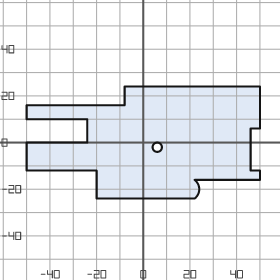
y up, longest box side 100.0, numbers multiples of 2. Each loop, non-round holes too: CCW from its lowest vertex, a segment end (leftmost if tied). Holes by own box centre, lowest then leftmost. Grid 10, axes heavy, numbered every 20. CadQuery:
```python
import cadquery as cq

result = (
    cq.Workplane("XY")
    .moveTo(-20.0, -24.0)
    .lineTo(22.0, -24.0)
    .threePointArc((24.0, -20.0), (22.0, -16.0))
    .lineTo(50.0, -16.0)
    .lineTo(50.0, -12.0)
    .lineTo(46.0, -12.0)
    .lineTo(46.0, 6.0)
    .lineTo(50.0, 6.0)
    .lineTo(50.0, 24.0)
    .lineTo(-8.0, 24.0)
    .lineTo(-8.0, 16.0)
    .lineTo(-50.0, 16.0)
    .lineTo(-50.0, 10.0)
    .lineTo(-24.0, 10.0)
    .lineTo(-24.0, 0.0)
    .lineTo(-50.0, 0.0)
    .lineTo(-50.0, -12.0)
    .lineTo(-20.0, -12.0)
    .close()
    .moveTo(6.0, -2.0)
    .circle(2.0)
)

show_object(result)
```